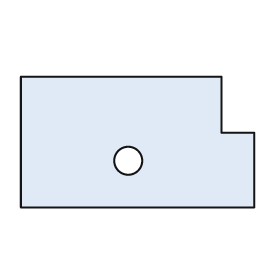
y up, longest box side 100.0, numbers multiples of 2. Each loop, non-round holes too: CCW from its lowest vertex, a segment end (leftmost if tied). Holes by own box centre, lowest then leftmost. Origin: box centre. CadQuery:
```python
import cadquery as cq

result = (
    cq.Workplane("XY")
    .moveTo(-50.0, -28.0)
    .lineTo(50.0, -28.0)
    .lineTo(50.0, 4.0)
    .lineTo(36.0, 4.0)
    .lineTo(36.0, 28.0)
    .lineTo(-50.0, 28.0)
    .close()
    .moveTo(-4.0, -8.0)
    .circle(6.0)
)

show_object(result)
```